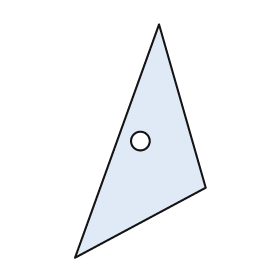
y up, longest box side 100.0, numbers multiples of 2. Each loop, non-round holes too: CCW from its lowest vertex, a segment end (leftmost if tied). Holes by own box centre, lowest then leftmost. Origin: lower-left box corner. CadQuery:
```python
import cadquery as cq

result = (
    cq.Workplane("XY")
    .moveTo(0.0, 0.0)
    .lineTo(56.0, 30.0)
    .lineTo(36.0, 100.0)
    .close()
    .moveTo(28.0, 50.0)
    .circle(4.0)
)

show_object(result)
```